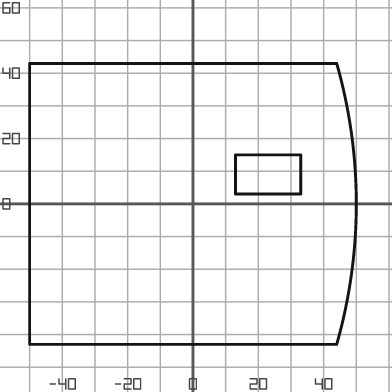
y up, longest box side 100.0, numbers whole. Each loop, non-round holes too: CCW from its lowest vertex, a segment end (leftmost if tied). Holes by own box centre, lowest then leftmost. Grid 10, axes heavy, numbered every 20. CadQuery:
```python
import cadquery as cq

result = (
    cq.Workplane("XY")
    .moveTo(-50.0, -43.0)
    .lineTo(44.0, -43.0)
    .threePointArc((50.0, 0.0), (44.0, 43.0))
    .lineTo(-50.0, 43.0)
    .close()
    .moveTo(13.0, 3.0)
    .lineTo(33.0, 3.0)
    .lineTo(33.0, 15.0)
    .lineTo(13.0, 15.0)
    .close()
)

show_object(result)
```